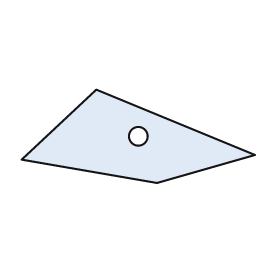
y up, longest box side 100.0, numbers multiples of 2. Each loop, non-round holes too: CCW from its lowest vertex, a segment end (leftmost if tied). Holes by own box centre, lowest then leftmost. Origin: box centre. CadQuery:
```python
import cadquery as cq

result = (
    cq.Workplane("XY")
    .moveTo(8.0, -20.0)
    .lineTo(50.0, -8.0)
    .lineTo(-18.0, 20.0)
    .lineTo(-50.0, -10.0)
    .close()
    .moveTo(0.0, 0.0)
    .circle(4.0)
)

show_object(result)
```